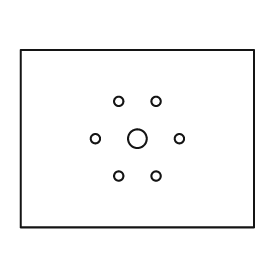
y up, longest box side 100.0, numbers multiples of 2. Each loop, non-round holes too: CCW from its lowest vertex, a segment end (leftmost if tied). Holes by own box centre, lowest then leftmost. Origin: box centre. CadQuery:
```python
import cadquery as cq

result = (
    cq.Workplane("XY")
    .moveTo(-50.0, -38.0)
    .lineTo(50.0, -38.0)
    .lineTo(50.0, 38.0)
    .lineTo(-50.0, 38.0)
    .close()
    .moveTo(-8.0, -16.0)
    .circle(2.0)
    .moveTo(8.0, -16.0)
    .circle(2.0)
    .moveTo(-18.0, 0.0)
    .circle(2.0)
    .moveTo(0.0, 0.0)
    .circle(4.0)
    .moveTo(18.0, 0.0)
    .circle(2.0)
    .moveTo(-8.0, 16.0)
    .circle(2.0)
    .moveTo(8.0, 16.0)
    .circle(2.0)
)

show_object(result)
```